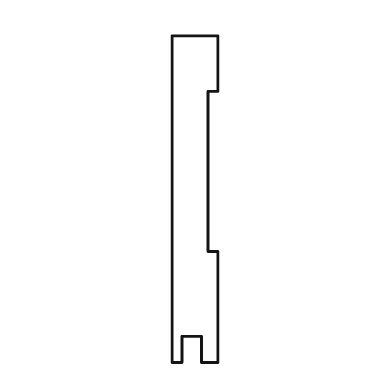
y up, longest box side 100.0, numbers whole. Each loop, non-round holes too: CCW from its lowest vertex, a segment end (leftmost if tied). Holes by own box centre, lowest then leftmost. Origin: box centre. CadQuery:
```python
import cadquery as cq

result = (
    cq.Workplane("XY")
    .moveTo(-7.0, -50.0)
    .lineTo(-4.0, -50.0)
    .lineTo(-4.0, -42.0)
    .lineTo(2.0, -42.0)
    .lineTo(2.0, -50.0)
    .lineTo(7.0, -50.0)
    .lineTo(7.0, -16.0)
    .lineTo(4.0, -16.0)
    .lineTo(4.0, 33.0)
    .lineTo(7.0, 33.0)
    .lineTo(7.0, 50.0)
    .lineTo(-7.0, 50.0)
    .close()
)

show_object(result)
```